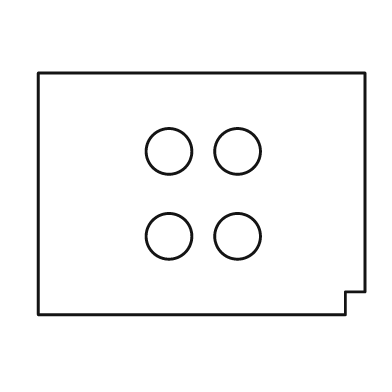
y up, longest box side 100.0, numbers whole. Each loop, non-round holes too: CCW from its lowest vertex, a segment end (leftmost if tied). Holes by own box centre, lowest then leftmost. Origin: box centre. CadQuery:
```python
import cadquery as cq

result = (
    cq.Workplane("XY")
    .moveTo(-50.0, -37.0)
    .lineTo(44.0, -37.0)
    .lineTo(44.0, -30.0)
    .lineTo(50.0, -30.0)
    .lineTo(50.0, 37.0)
    .lineTo(-50.0, 37.0)
    .close()
    .moveTo(-10.0, -13.0)
    .circle(7.0)
    .moveTo(11.0, -13.0)
    .circle(7.0)
    .moveTo(-10.0, 13.0)
    .circle(7.0)
    .moveTo(11.0, 13.0)
    .circle(7.0)
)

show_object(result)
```